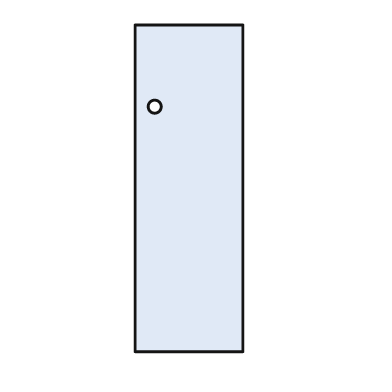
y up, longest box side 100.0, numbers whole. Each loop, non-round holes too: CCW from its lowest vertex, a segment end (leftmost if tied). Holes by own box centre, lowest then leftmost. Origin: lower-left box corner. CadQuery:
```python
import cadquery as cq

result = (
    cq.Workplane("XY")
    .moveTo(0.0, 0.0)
    .lineTo(33.0, 0.0)
    .lineTo(33.0, 100.0)
    .lineTo(0.0, 100.0)
    .close()
    .moveTo(6.0, 75.0)
    .circle(2.0)
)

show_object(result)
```